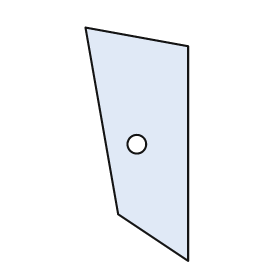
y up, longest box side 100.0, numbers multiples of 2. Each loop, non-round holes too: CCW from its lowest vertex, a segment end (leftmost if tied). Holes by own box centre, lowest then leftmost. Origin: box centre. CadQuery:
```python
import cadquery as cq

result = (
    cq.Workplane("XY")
    .moveTo(22.0, -50.0)
    .lineTo(22.0, 42.0)
    .lineTo(-22.0, 50.0)
    .lineTo(-8.0, -30.0)
    .close()
    .moveTo(0.0, 0.0)
    .circle(4.0)
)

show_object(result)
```